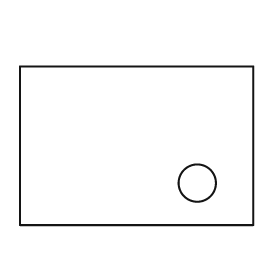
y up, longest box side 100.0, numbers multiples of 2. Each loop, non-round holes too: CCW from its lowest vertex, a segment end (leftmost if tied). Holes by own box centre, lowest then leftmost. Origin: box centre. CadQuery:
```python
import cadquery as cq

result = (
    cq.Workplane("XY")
    .moveTo(-50.0, -34.0)
    .lineTo(50.0, -34.0)
    .lineTo(50.0, 34.0)
    .lineTo(-50.0, 34.0)
    .close()
    .moveTo(26.0, -16.0)
    .circle(8.0)
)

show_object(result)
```